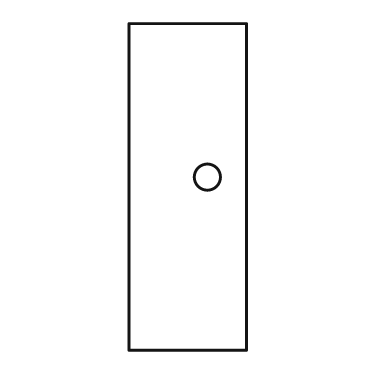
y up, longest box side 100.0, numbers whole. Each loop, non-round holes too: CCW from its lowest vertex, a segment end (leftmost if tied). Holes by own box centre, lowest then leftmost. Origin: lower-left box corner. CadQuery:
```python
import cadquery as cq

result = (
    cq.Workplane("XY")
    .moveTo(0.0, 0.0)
    .lineTo(36.0, 0.0)
    .lineTo(36.0, 100.0)
    .lineTo(0.0, 100.0)
    .close()
    .moveTo(24.0, 53.0)
    .circle(4.0)
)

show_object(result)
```